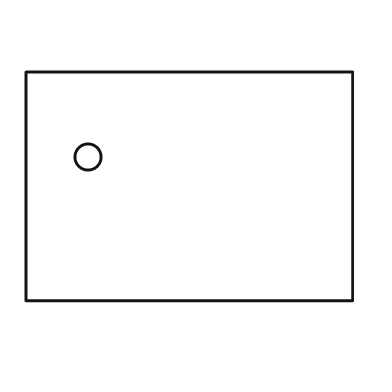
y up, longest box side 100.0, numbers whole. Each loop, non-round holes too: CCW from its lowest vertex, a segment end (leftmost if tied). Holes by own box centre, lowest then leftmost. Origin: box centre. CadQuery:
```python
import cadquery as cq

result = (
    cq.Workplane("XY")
    .moveTo(-50.0, -35.0)
    .lineTo(50.0, -35.0)
    .lineTo(50.0, 35.0)
    .lineTo(-50.0, 35.0)
    .close()
    .moveTo(-31.0, 9.0)
    .circle(4.0)
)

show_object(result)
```